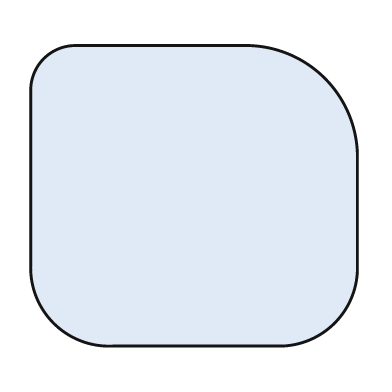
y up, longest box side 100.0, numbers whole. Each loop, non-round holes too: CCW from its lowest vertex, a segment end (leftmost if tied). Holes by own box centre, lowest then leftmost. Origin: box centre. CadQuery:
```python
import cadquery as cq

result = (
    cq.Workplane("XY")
    .moveTo(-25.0, -46.0)
    .lineTo(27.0, -46.0)
    .threePointArc((43.0, -39.0), (50.0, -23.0))
    .lineTo(50.0, 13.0)
    .threePointArc((40.0, 36.0), (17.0, 46.0))
    .lineTo(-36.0, 46.0)
    .threePointArc((-46.0, 42.0), (-50.0, 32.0))
    .lineTo(-50.0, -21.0)
    .threePointArc((-43.0, -39.0), (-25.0, -46.0))
    .close()
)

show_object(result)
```